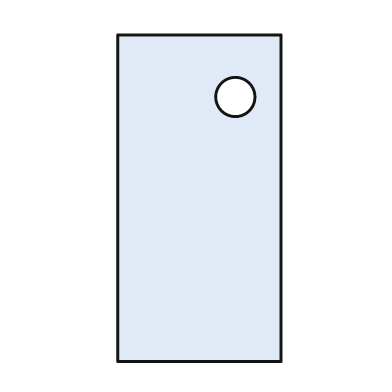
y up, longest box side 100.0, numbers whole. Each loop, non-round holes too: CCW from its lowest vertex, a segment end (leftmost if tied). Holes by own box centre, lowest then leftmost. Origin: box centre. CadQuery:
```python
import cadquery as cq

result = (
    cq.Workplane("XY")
    .moveTo(-25.0, -50.0)
    .lineTo(25.0, -50.0)
    .lineTo(25.0, 50.0)
    .lineTo(-25.0, 50.0)
    .close()
    .moveTo(11.0, 31.0)
    .circle(6.0)
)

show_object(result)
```